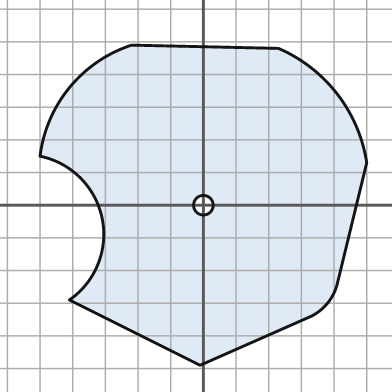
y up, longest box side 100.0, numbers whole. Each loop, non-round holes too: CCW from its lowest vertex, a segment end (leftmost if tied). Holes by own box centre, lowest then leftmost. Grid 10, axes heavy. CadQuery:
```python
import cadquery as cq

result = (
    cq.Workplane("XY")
    .moveTo(-1.0, -49.0)
    .lineTo(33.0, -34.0)
    .threePointArc((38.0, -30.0), (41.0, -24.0))
    .lineTo(50.0, 13.0)
    .threePointArc((41.0, 34.0), (23.0, 48.0))
    .lineTo(-22.0, 49.0)
    .threePointArc((-41.0, 36.0), (-50.0, 15.0))
    .threePointArc((-31.0, -4.0), (-41.0, -29.0))
    .close()
    .moveTo(0.0, 0.0)
    .circle(3.0)
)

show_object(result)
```